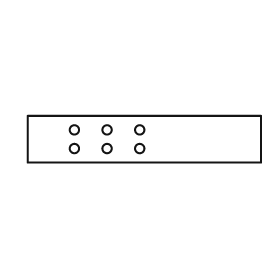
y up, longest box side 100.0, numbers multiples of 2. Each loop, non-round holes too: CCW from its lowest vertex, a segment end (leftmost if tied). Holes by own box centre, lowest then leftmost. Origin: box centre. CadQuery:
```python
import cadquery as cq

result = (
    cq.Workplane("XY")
    .moveTo(-50.0, -10.0)
    .lineTo(50.0, -10.0)
    .lineTo(50.0, 10.0)
    .lineTo(-50.0, 10.0)
    .close()
    .moveTo(-30.0, -4.0)
    .circle(2.0)
    .moveTo(-16.0, -4.0)
    .circle(2.0)
    .moveTo(-2.0, -4.0)
    .circle(2.0)
    .moveTo(-30.0, 4.0)
    .circle(2.0)
    .moveTo(-16.0, 4.0)
    .circle(2.0)
    .moveTo(-2.0, 4.0)
    .circle(2.0)
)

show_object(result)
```